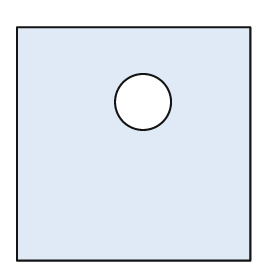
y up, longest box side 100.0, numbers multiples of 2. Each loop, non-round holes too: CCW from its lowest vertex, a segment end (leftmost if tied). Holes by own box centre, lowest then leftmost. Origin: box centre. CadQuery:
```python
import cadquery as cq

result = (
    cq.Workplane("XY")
    .moveTo(-50.0, -50.0)
    .lineTo(50.0, -50.0)
    .lineTo(50.0, 50.0)
    .lineTo(-50.0, 50.0)
    .close()
    .moveTo(4.0, 18.0)
    .circle(12.0)
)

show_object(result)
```